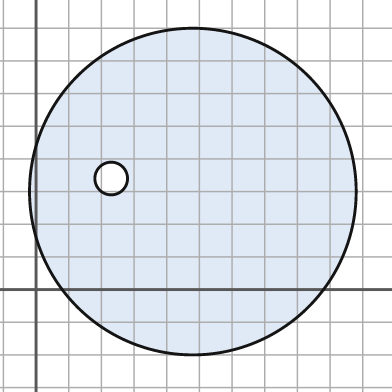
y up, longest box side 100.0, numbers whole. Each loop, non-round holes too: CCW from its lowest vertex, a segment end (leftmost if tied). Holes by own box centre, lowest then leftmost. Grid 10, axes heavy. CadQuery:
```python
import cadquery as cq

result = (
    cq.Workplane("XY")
    .moveTo(48.0, 30.0)
    .circle(50.0)
    .moveTo(23.0, 34.0)
    .circle(5.0)
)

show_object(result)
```